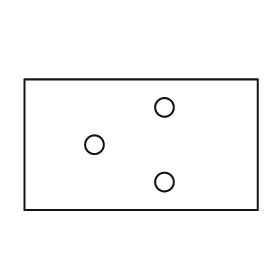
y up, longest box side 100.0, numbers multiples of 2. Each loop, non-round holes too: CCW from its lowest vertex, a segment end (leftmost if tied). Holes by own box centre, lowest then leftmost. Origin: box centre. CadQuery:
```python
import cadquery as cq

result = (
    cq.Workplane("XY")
    .moveTo(-50.0, -28.0)
    .lineTo(50.0, -28.0)
    .lineTo(50.0, 28.0)
    .lineTo(-50.0, 28.0)
    .close()
    .moveTo(10.0, -16.0)
    .circle(4.0)
    .moveTo(-20.0, 0.0)
    .circle(4.0)
    .moveTo(10.0, 16.0)
    .circle(4.0)
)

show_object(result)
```